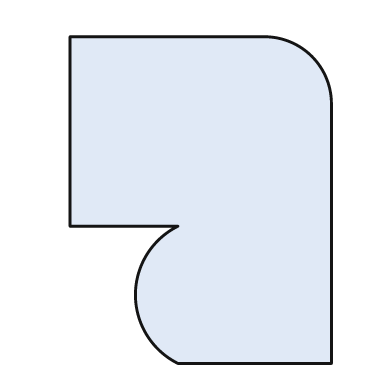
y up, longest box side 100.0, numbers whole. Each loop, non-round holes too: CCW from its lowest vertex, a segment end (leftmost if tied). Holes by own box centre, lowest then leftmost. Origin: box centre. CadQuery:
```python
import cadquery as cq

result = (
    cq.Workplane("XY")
    .moveTo(-7.0, -50.0)
    .lineTo(40.0, -50.0)
    .lineTo(40.0, 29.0)
    .threePointArc((34.0, 44.0), (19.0, 50.0))
    .lineTo(-40.0, 50.0)
    .lineTo(-40.0, -8.0)
    .lineTo(-7.0, -8.0)
    .threePointArc((-20.0, -29.0), (-7.0, -50.0))
    .close()
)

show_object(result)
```